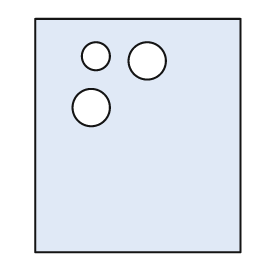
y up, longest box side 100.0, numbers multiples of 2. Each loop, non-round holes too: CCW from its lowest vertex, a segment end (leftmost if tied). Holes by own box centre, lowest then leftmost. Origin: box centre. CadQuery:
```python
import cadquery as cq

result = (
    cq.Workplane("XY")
    .moveTo(-44.0, -50.0)
    .lineTo(44.0, -50.0)
    .lineTo(44.0, 50.0)
    .lineTo(-44.0, 50.0)
    .close()
    .moveTo(-20.0, 12.0)
    .circle(8.0)
    .moveTo(4.0, 32.0)
    .circle(8.0)
    .moveTo(-18.0, 34.0)
    .circle(6.0)
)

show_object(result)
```